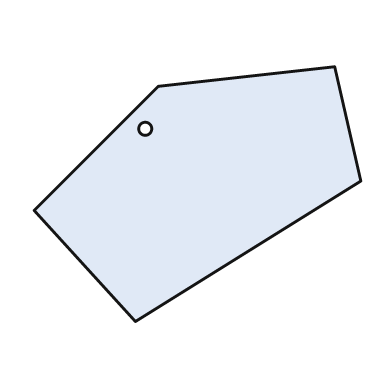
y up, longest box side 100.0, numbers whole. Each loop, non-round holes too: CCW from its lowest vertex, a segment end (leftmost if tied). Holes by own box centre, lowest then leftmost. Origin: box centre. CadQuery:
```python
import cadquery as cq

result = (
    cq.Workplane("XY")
    .moveTo(-19.0, -39.0)
    .lineTo(50.0, 4.0)
    .lineTo(42.0, 39.0)
    .lineTo(-12.0, 33.0)
    .lineTo(-50.0, -5.0)
    .close()
    .moveTo(-16.0, 20.0)
    .circle(2.0)
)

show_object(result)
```